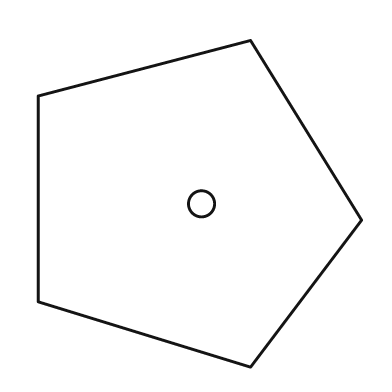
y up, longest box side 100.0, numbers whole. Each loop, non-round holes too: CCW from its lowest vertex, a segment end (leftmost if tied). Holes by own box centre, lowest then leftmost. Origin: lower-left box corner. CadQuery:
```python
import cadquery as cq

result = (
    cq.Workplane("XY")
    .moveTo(65.0, 0.0)
    .lineTo(99.0, 45.0)
    .lineTo(65.0, 100.0)
    .lineTo(0.0, 83.0)
    .lineTo(0.0, 20.0)
    .close()
    .moveTo(50.0, 50.0)
    .circle(4.0)
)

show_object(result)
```